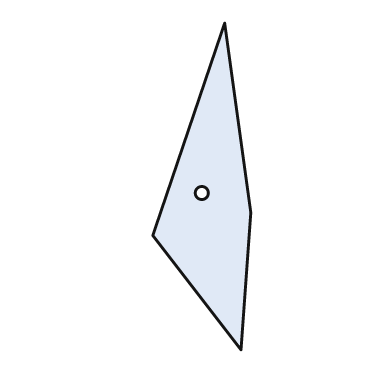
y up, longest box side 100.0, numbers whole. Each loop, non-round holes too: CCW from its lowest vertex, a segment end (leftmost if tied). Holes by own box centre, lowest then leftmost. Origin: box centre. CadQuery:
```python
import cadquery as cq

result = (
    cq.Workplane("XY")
    .moveTo(12.0, -50.0)
    .lineTo(15.0, -8.0)
    .lineTo(7.0, 50.0)
    .lineTo(-15.0, -15.0)
    .close()
    .moveTo(0.0, -2.0)
    .circle(2.0)
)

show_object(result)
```